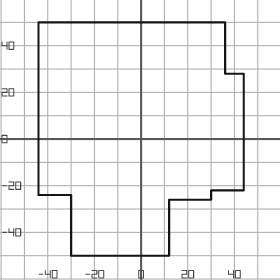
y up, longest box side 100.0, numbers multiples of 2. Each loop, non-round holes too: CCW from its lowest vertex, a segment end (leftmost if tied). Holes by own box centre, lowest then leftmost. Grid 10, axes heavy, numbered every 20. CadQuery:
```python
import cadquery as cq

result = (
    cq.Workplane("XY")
    .moveTo(-30.0, -50.0)
    .lineTo(12.0, -50.0)
    .lineTo(12.0, -26.0)
    .lineTo(30.0, -26.0)
    .lineTo(30.0, -22.0)
    .lineTo(44.0, -22.0)
    .lineTo(44.0, 28.0)
    .lineTo(36.0, 28.0)
    .lineTo(36.0, 50.0)
    .lineTo(-44.0, 50.0)
    .lineTo(-44.0, -24.0)
    .lineTo(-30.0, -24.0)
    .close()
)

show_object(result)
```